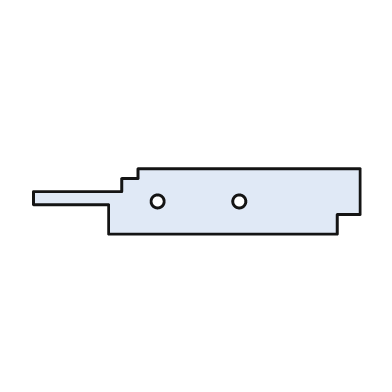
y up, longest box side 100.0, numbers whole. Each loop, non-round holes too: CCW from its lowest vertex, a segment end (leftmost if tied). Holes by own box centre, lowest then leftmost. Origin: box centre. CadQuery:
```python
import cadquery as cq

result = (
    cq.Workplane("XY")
    .moveTo(-27.0, -10.0)
    .lineTo(43.0, -10.0)
    .lineTo(43.0, -4.0)
    .lineTo(50.0, -4.0)
    .lineTo(50.0, 10.0)
    .lineTo(-18.0, 10.0)
    .lineTo(-18.0, 7.0)
    .lineTo(-23.0, 7.0)
    .lineTo(-23.0, 3.0)
    .lineTo(-50.0, 3.0)
    .lineTo(-50.0, -1.0)
    .lineTo(-27.0, -1.0)
    .close()
    .moveTo(-12.0, 0.0)
    .circle(2.0)
    .moveTo(13.0, 0.0)
    .circle(2.0)
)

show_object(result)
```